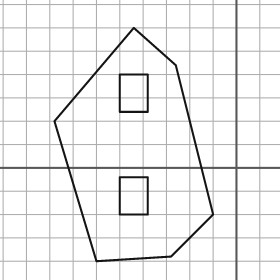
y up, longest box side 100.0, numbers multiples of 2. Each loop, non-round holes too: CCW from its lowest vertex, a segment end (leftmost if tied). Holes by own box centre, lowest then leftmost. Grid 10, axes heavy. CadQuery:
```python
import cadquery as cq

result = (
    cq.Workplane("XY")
    .moveTo(-60.0, -40.0)
    .lineTo(-28.0, -38.0)
    .lineTo(-10.0, -20.0)
    .lineTo(-26.0, 44.0)
    .lineTo(-44.0, 60.0)
    .lineTo(-78.0, 20.0)
    .close()
    .moveTo(-50.0, -20.0)
    .lineTo(-38.0, -20.0)
    .lineTo(-38.0, -4.0)
    .lineTo(-50.0, -4.0)
    .close()
    .moveTo(-50.0, 24.0)
    .lineTo(-38.0, 24.0)
    .lineTo(-38.0, 40.0)
    .lineTo(-50.0, 40.0)
    .close()
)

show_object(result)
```